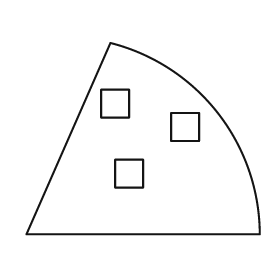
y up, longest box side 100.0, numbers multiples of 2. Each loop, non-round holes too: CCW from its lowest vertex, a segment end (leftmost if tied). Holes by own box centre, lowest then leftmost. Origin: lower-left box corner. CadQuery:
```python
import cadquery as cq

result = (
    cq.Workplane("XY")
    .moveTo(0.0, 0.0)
    .lineTo(100.0, 0.0)
    .threePointArc((82.0, 52.0), (36.0, 82.0))
    .close()
    .moveTo(38.0, 20.0)
    .lineTo(50.0, 20.0)
    .lineTo(50.0, 32.0)
    .lineTo(38.0, 32.0)
    .close()
    .moveTo(62.0, 40.0)
    .lineTo(74.0, 40.0)
    .lineTo(74.0, 52.0)
    .lineTo(62.0, 52.0)
    .close()
    .moveTo(32.0, 50.0)
    .lineTo(44.0, 50.0)
    .lineTo(44.0, 62.0)
    .lineTo(32.0, 62.0)
    .close()
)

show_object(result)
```